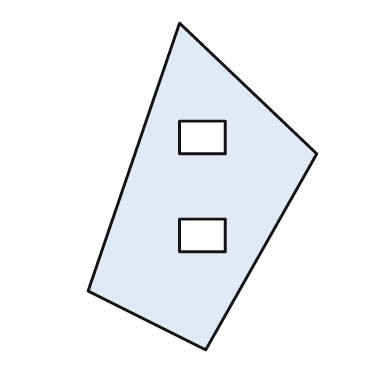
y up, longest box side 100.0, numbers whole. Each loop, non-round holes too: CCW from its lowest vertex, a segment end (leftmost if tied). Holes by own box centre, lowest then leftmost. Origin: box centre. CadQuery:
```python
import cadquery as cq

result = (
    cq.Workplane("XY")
    .moveTo(1.0, -50.0)
    .lineTo(35.0, 10.0)
    .lineTo(-7.0, 50.0)
    .lineTo(-35.0, -32.0)
    .close()
    .moveTo(-7.0, -20.0)
    .lineTo(7.0, -20.0)
    .lineTo(7.0, -10.0)
    .lineTo(-7.0, -10.0)
    .close()
    .moveTo(-7.0, 10.0)
    .lineTo(7.0, 10.0)
    .lineTo(7.0, 20.0)
    .lineTo(-7.0, 20.0)
    .close()
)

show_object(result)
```